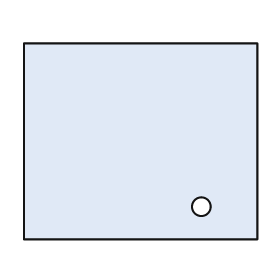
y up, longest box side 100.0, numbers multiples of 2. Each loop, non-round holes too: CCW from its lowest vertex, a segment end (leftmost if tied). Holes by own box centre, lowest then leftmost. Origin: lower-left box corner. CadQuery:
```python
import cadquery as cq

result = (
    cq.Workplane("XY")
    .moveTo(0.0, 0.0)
    .lineTo(100.0, 0.0)
    .lineTo(100.0, 84.0)
    .lineTo(0.0, 84.0)
    .close()
    .moveTo(76.0, 14.0)
    .circle(4.0)
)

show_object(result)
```